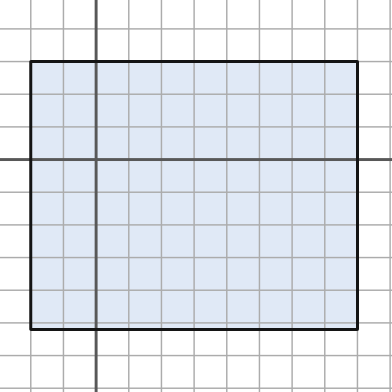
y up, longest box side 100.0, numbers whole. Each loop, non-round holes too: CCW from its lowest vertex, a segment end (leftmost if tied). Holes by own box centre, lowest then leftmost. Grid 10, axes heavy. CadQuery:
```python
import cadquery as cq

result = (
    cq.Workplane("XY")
    .moveTo(-20.0, -52.0)
    .lineTo(80.0, -52.0)
    .lineTo(80.0, 30.0)
    .lineTo(-20.0, 30.0)
    .close()
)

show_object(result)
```